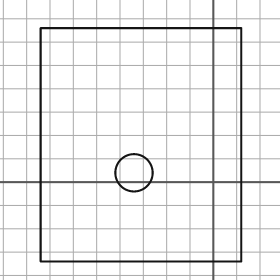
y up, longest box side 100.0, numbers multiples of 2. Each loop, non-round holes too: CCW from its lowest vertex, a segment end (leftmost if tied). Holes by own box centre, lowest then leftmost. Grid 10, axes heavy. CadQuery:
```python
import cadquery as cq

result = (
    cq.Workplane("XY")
    .moveTo(-74.0, -34.0)
    .lineTo(12.0, -34.0)
    .lineTo(12.0, 66.0)
    .lineTo(-74.0, 66.0)
    .close()
    .moveTo(-34.0, 4.0)
    .circle(8.0)
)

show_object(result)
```